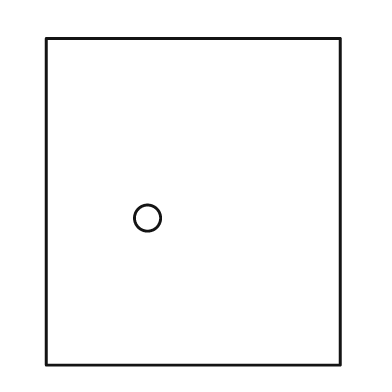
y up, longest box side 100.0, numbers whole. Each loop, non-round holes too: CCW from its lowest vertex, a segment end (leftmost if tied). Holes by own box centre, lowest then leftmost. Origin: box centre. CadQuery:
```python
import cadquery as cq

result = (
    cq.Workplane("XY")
    .moveTo(-45.0, -50.0)
    .lineTo(45.0, -50.0)
    .lineTo(45.0, 50.0)
    .lineTo(-45.0, 50.0)
    .close()
    .moveTo(-14.0, -5.0)
    .circle(4.0)
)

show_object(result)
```